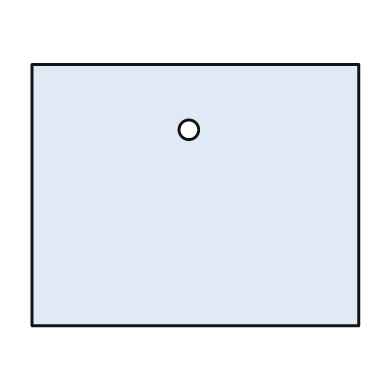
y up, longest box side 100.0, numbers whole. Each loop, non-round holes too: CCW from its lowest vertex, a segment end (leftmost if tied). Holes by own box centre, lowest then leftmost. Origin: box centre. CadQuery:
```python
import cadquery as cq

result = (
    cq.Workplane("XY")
    .moveTo(-50.0, -40.0)
    .lineTo(50.0, -40.0)
    .lineTo(50.0, 40.0)
    .lineTo(-50.0, 40.0)
    .close()
    .moveTo(-2.0, 20.0)
    .circle(3.0)
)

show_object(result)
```